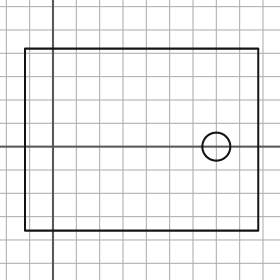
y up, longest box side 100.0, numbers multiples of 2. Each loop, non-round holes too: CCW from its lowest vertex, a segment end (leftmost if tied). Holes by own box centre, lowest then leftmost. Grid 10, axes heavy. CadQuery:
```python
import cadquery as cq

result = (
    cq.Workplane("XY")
    .moveTo(-12.0, -36.0)
    .lineTo(88.0, -36.0)
    .lineTo(88.0, 42.0)
    .lineTo(-12.0, 42.0)
    .close()
    .moveTo(70.0, 0.0)
    .circle(6.0)
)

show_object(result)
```